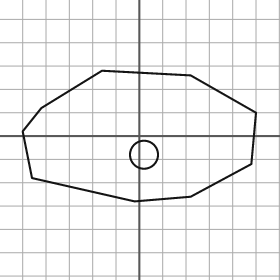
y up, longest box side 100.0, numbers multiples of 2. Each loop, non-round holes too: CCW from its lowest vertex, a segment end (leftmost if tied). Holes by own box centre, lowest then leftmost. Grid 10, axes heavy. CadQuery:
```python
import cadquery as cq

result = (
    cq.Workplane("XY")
    .moveTo(-2.0, -28.0)
    .lineTo(22.0, -26.0)
    .lineTo(48.0, -12.0)
    .lineTo(50.0, 10.0)
    .lineTo(22.0, 26.0)
    .lineTo(-16.0, 28.0)
    .lineTo(-42.0, 12.0)
    .lineTo(-50.0, 2.0)
    .lineTo(-46.0, -18.0)
    .close()
    .moveTo(2.0, -8.0)
    .circle(6.0)
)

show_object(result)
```